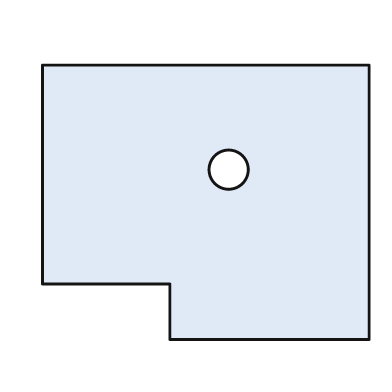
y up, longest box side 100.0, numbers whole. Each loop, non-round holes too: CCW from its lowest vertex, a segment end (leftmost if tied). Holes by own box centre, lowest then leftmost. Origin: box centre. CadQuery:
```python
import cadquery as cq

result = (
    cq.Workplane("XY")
    .moveTo(-11.0, -42.0)
    .lineTo(50.0, -42.0)
    .lineTo(50.0, 42.0)
    .lineTo(-50.0, 42.0)
    .lineTo(-50.0, -25.0)
    .lineTo(-11.0, -25.0)
    .close()
    .moveTo(7.0, 10.0)
    .circle(6.0)
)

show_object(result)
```